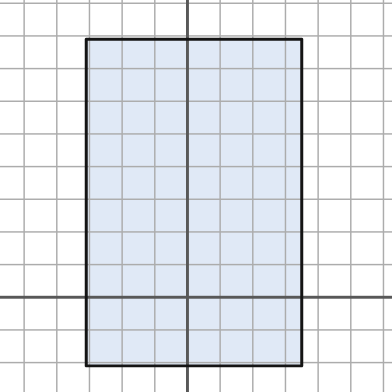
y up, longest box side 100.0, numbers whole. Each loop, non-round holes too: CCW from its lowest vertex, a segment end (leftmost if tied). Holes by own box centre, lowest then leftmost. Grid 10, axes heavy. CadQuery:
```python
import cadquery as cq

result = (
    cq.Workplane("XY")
    .moveTo(-31.0, -21.0)
    .lineTo(35.0, -21.0)
    .lineTo(35.0, 79.0)
    .lineTo(-31.0, 79.0)
    .close()
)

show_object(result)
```